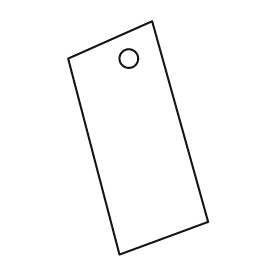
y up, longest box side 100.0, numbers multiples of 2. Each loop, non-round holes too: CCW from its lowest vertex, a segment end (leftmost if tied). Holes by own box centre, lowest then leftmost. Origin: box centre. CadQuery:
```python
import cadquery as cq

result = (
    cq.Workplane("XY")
    .moveTo(-8.0, -50.0)
    .lineTo(30.0, -36.0)
    .lineTo(6.0, 50.0)
    .lineTo(-30.0, 34.0)
    .close()
    .moveTo(-4.0, 34.0)
    .circle(4.0)
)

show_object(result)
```